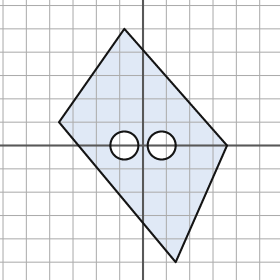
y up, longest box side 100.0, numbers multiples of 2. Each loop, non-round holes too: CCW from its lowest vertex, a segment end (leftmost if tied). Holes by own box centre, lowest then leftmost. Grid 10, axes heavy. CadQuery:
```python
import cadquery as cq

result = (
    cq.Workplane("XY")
    .moveTo(14.0, -50.0)
    .lineTo(36.0, 0.0)
    .lineTo(-8.0, 50.0)
    .lineTo(-36.0, 10.0)
    .close()
    .moveTo(-8.0, 0.0)
    .circle(6.0)
    .moveTo(8.0, 0.0)
    .circle(6.0)
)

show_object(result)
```